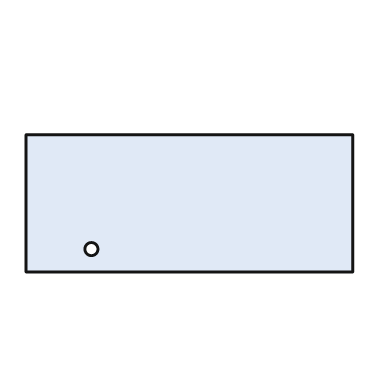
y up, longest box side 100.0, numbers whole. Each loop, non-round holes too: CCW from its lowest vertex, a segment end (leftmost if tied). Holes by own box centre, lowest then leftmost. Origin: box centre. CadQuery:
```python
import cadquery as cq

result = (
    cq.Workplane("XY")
    .moveTo(-50.0, -21.0)
    .lineTo(50.0, -21.0)
    .lineTo(50.0, 21.0)
    .lineTo(-50.0, 21.0)
    .close()
    .moveTo(-30.0, -14.0)
    .circle(2.0)
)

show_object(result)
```